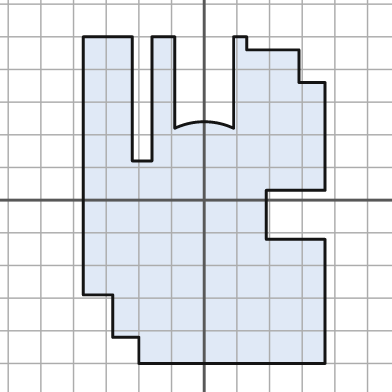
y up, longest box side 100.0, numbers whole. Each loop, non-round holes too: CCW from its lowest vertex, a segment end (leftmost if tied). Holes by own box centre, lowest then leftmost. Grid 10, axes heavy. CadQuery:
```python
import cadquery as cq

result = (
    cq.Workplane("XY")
    .moveTo(-20.0, -50.0)
    .lineTo(37.0, -50.0)
    .lineTo(37.0, -12.0)
    .lineTo(19.0, -12.0)
    .lineTo(19.0, 3.0)
    .lineTo(37.0, 3.0)
    .lineTo(37.0, 36.0)
    .lineTo(29.0, 36.0)
    .lineTo(29.0, 46.0)
    .lineTo(13.0, 46.0)
    .lineTo(13.0, 50.0)
    .lineTo(9.0, 50.0)
    .lineTo(9.0, 22.0)
    .threePointArc((0.0, 24.0), (-9.0, 22.0))
    .lineTo(-9.0, 50.0)
    .lineTo(-16.0, 50.0)
    .lineTo(-16.0, 12.0)
    .lineTo(-22.0, 12.0)
    .lineTo(-22.0, 50.0)
    .lineTo(-37.0, 50.0)
    .lineTo(-37.0, -29.0)
    .lineTo(-28.0, -29.0)
    .lineTo(-28.0, -42.0)
    .lineTo(-20.0, -42.0)
    .close()
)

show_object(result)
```